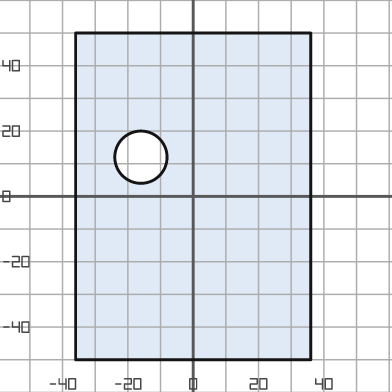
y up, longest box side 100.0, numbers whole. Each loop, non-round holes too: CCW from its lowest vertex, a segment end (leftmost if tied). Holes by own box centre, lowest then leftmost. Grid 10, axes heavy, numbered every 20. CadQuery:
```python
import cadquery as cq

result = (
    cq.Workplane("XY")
    .moveTo(-36.0, -50.0)
    .lineTo(36.0, -50.0)
    .lineTo(36.0, 50.0)
    .lineTo(-36.0, 50.0)
    .close()
    .moveTo(-16.0, 12.0)
    .circle(8.0)
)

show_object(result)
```